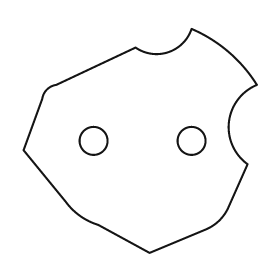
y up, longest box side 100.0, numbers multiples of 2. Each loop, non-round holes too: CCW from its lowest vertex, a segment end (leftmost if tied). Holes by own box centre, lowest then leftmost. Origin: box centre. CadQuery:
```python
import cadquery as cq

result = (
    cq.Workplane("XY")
    .moveTo(4.0, -48.0)
    .lineTo(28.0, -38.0)
    .threePointArc((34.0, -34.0), (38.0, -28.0))
    .lineTo(46.0, -10.0)
    .threePointArc((38.0, 8.0), (50.0, 24.0))
    .threePointArc((38.0, 38.0), (22.0, 48.0))
    .threePointArc((12.0, 38.0), (-2.0, 40.0))
    .lineTo(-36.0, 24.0)
    .threePointArc((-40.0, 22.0), (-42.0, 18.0))
    .lineTo(-50.0, -4.0)
    .lineTo(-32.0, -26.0)
    .threePointArc((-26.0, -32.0), (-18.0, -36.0))
    .close()
    .moveTo(-20.0, 0.0)
    .circle(6.0)
    .moveTo(22.0, 0.0)
    .circle(6.0)
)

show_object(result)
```